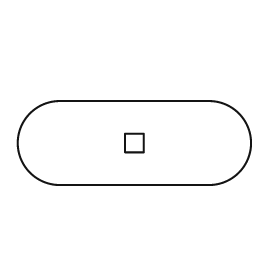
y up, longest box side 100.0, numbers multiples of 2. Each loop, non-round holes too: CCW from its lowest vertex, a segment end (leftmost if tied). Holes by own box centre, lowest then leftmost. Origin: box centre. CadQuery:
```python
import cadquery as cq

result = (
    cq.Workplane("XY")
    .moveTo(-32.0, -18.0)
    .lineTo(32.0, -18.0)
    .threePointArc((50.0, 0.0), (32.0, 18.0))
    .lineTo(-32.0, 18.0)
    .threePointArc((-50.0, 0.0), (-32.0, -18.0))
    .close()
    .moveTo(-4.0, -4.0)
    .lineTo(4.0, -4.0)
    .lineTo(4.0, 4.0)
    .lineTo(-4.0, 4.0)
    .close()
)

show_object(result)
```